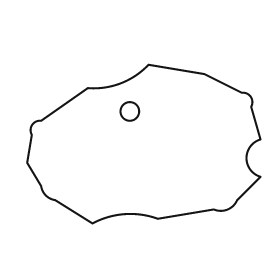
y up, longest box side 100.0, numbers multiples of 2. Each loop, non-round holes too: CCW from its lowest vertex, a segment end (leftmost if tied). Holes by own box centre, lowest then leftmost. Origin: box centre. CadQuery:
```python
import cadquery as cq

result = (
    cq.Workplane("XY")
    .moveTo(-22.0, -34.0)
    .threePointArc((-8.0, -30.0), (6.0, -32.0))
    .lineTo(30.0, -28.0)
    .threePointArc((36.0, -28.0), (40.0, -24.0))
    .lineTo(50.0, -14.0)
    .threePointArc((44.0, -6.0), (50.0, 2.0))
    .lineTo(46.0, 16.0)
    .threePointArc((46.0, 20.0), (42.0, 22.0))
    .lineTo(26.0, 30.0)
    .lineTo(2.0, 34.0)
    .threePointArc((-10.0, 26.0), (-24.0, 24.0))
    .lineTo(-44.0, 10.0)
    .threePointArc((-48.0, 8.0), (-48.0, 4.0))
    .lineTo(-50.0, -8.0)
    .lineTo(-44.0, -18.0)
    .threePointArc((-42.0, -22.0), (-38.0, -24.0))
    .close()
    .moveTo(-6.0, 14.0)
    .circle(4.0)
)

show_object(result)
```